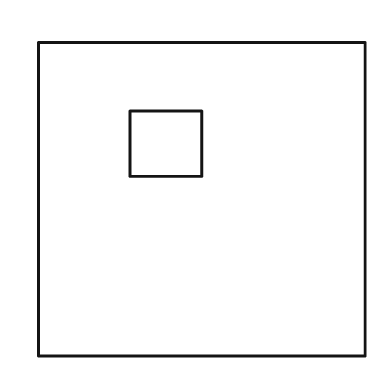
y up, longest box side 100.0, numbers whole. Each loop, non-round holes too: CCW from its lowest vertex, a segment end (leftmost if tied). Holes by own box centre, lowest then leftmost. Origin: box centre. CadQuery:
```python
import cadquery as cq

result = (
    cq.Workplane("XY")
    .moveTo(-50.0, -48.0)
    .lineTo(50.0, -48.0)
    .lineTo(50.0, 48.0)
    .lineTo(-50.0, 48.0)
    .close()
    .moveTo(-22.0, 7.0)
    .lineTo(0.0, 7.0)
    .lineTo(0.0, 27.0)
    .lineTo(-22.0, 27.0)
    .close()
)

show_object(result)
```